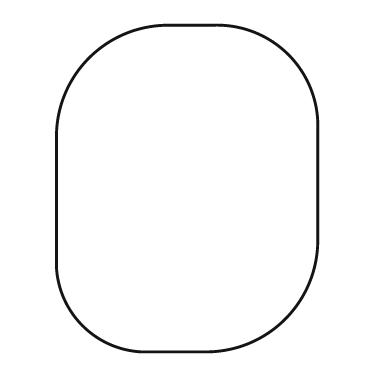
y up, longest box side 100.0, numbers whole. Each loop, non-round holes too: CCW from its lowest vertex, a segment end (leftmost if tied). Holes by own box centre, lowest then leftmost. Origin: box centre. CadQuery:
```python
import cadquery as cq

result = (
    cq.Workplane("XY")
    .moveTo(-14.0, -50.0)
    .lineTo(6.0, -50.0)
    .threePointArc((30.0, -40.0), (40.0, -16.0))
    .lineTo(40.0, 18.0)
    .threePointArc((31.0, 41.0), (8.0, 50.0))
    .lineTo(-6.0, 50.0)
    .threePointArc((-30.0, 40.0), (-40.0, 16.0))
    .lineTo(-40.0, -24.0)
    .threePointArc((-32.0, -42.0), (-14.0, -50.0))
    .close()
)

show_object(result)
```